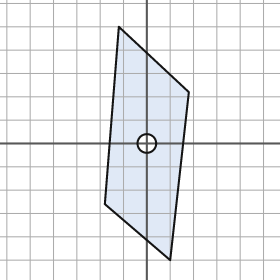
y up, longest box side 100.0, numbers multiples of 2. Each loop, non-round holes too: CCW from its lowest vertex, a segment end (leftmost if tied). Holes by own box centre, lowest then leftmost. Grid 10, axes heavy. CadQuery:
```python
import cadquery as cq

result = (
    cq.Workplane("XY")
    .moveTo(10.0, -50.0)
    .lineTo(18.0, 22.0)
    .lineTo(-12.0, 50.0)
    .lineTo(-18.0, -26.0)
    .close()
    .moveTo(0.0, 0.0)
    .circle(4.0)
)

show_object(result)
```